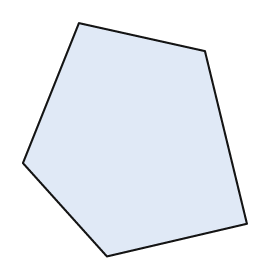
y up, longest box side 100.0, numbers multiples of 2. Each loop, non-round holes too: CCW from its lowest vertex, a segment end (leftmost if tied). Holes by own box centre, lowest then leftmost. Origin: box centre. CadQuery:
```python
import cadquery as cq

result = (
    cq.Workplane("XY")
    .moveTo(-12.0, -50.0)
    .lineTo(48.0, -36.0)
    .lineTo(30.0, 38.0)
    .lineTo(-24.0, 50.0)
    .lineTo(-48.0, -10.0)
    .close()
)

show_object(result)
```